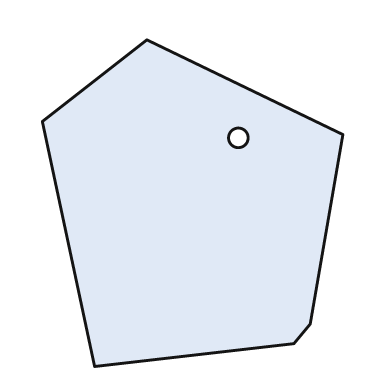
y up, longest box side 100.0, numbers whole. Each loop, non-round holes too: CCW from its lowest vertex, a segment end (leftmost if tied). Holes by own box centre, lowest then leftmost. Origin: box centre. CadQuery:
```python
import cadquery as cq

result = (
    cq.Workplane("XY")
    .moveTo(-30.0, -50.0)
    .lineTo(31.0, -43.0)
    .lineTo(36.0, -37.0)
    .lineTo(46.0, 21.0)
    .lineTo(-14.0, 50.0)
    .lineTo(-46.0, 25.0)
    .close()
    .moveTo(14.0, 20.0)
    .circle(3.0)
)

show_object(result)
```